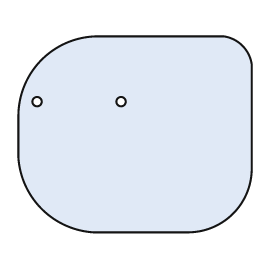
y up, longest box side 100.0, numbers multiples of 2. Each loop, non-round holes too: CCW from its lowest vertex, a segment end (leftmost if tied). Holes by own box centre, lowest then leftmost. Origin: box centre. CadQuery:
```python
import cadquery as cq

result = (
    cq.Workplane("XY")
    .moveTo(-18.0, -42.0)
    .lineTo(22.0, -42.0)
    .threePointArc((42.0, -34.0), (50.0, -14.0))
    .lineTo(50.0, 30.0)
    .threePointArc((46.0, 38.0), (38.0, 42.0))
    .lineTo(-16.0, 42.0)
    .threePointArc((-40.0, 32.0), (-50.0, 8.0))
    .lineTo(-50.0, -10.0)
    .threePointArc((-40.0, -32.0), (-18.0, -42.0))
    .close()
    .moveTo(-42.0, 14.0)
    .circle(2.0)
    .moveTo(-6.0, 14.0)
    .circle(2.0)
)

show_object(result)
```